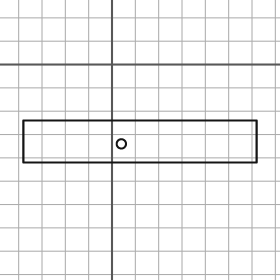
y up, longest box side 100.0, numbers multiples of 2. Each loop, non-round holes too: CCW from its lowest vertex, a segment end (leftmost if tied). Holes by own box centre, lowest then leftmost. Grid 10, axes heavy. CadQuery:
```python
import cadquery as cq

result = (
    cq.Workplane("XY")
    .moveTo(-38.0, -42.0)
    .lineTo(62.0, -42.0)
    .lineTo(62.0, -24.0)
    .lineTo(-38.0, -24.0)
    .close()
    .moveTo(4.0, -34.0)
    .circle(2.0)
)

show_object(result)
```